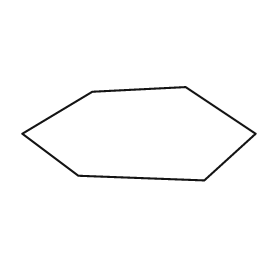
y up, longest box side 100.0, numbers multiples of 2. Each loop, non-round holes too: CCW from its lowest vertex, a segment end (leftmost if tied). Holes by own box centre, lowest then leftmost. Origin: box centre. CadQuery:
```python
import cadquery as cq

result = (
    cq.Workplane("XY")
    .moveTo(28.0, -20.0)
    .lineTo(50.0, 0.0)
    .lineTo(20.0, 20.0)
    .lineTo(-20.0, 18.0)
    .lineTo(-50.0, 0.0)
    .lineTo(-26.0, -18.0)
    .close()
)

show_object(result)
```